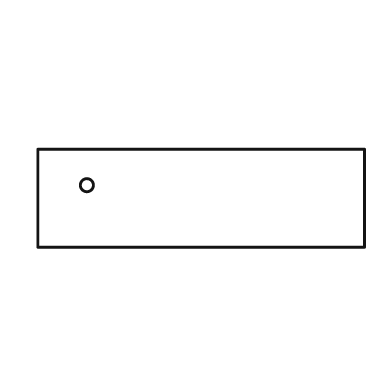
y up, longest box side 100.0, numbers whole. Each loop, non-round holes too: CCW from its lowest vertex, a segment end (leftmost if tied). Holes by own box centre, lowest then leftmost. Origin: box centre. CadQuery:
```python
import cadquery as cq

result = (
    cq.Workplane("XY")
    .moveTo(-50.0, -15.0)
    .lineTo(50.0, -15.0)
    .lineTo(50.0, 15.0)
    .lineTo(-50.0, 15.0)
    .close()
    .moveTo(-35.0, 4.0)
    .circle(2.0)
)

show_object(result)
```